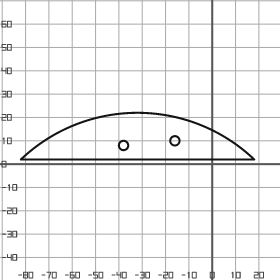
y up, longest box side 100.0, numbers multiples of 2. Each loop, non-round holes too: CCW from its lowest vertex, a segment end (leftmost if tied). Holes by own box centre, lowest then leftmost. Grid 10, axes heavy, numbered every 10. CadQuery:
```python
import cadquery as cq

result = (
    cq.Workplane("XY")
    .moveTo(-82.0, 2.0)
    .lineTo(18.0, 2.0)
    .threePointArc((-32.0, 22.0), (-82.0, 2.0))
    .close()
    .moveTo(-38.0, 8.0)
    .circle(2.0)
    .moveTo(-16.0, 10.0)
    .circle(2.0)
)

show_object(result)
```